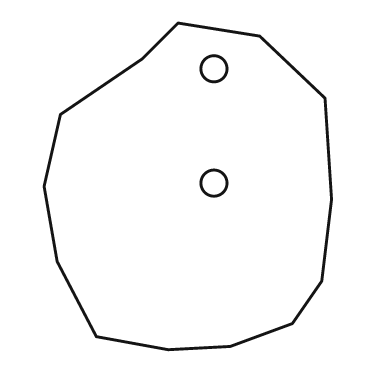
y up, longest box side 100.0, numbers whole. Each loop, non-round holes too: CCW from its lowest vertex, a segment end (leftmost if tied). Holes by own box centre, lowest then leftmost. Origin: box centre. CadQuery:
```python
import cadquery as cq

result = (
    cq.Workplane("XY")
    .moveTo(-6.0, -50.0)
    .lineTo(13.0, -49.0)
    .lineTo(32.0, -42.0)
    .lineTo(41.0, -29.0)
    .lineTo(44.0, -4.0)
    .lineTo(42.0, 27.0)
    .lineTo(22.0, 46.0)
    .lineTo(-3.0, 50.0)
    .lineTo(-14.0, 39.0)
    .lineTo(-39.0, 22.0)
    .lineTo(-44.0, 0.0)
    .lineTo(-40.0, -23.0)
    .lineTo(-28.0, -46.0)
    .close()
    .moveTo(8.0, 1.0)
    .circle(4.0)
    .moveTo(8.0, 36.0)
    .circle(4.0)
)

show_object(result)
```